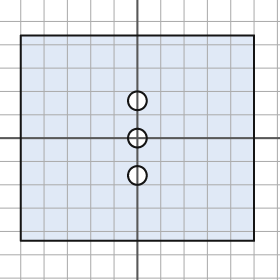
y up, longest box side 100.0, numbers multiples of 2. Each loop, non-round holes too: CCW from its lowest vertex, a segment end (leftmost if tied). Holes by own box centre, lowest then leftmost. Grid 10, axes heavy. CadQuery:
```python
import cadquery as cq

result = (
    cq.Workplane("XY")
    .moveTo(-50.0, -44.0)
    .lineTo(50.0, -44.0)
    .lineTo(50.0, 44.0)
    .lineTo(-50.0, 44.0)
    .close()
    .moveTo(0.0, -16.0)
    .circle(4.0)
    .moveTo(0.0, 0.0)
    .circle(4.0)
    .moveTo(0.0, 16.0)
    .circle(4.0)
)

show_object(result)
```